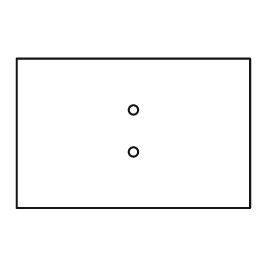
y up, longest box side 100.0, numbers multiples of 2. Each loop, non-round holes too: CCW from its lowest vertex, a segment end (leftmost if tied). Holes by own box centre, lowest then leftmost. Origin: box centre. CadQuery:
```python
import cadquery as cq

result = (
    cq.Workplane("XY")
    .moveTo(-50.0, -32.0)
    .lineTo(50.0, -32.0)
    .lineTo(50.0, 32.0)
    .lineTo(-50.0, 32.0)
    .close()
    .moveTo(0.0, -8.0)
    .circle(2.0)
    .moveTo(0.0, 10.0)
    .circle(2.0)
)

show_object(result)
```